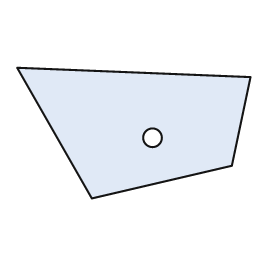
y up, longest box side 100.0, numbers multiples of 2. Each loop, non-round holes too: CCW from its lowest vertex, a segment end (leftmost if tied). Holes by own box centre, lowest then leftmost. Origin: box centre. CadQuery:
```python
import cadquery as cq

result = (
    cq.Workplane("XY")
    .moveTo(-18.0, -28.0)
    .lineTo(42.0, -14.0)
    .lineTo(50.0, 24.0)
    .lineTo(-50.0, 28.0)
    .close()
    .moveTo(8.0, -2.0)
    .circle(4.0)
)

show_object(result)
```